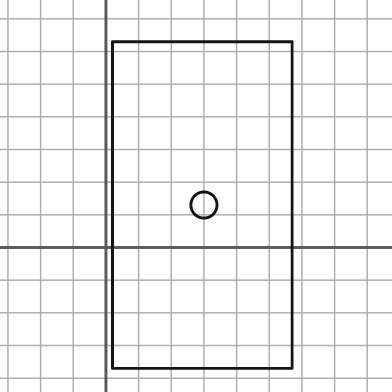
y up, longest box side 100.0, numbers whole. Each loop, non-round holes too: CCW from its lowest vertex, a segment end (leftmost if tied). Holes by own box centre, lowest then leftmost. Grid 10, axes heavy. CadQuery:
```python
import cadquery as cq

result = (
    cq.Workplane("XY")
    .moveTo(2.0, -37.0)
    .lineTo(57.0, -37.0)
    .lineTo(57.0, 63.0)
    .lineTo(2.0, 63.0)
    .close()
    .moveTo(30.0, 13.0)
    .circle(4.0)
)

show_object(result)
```